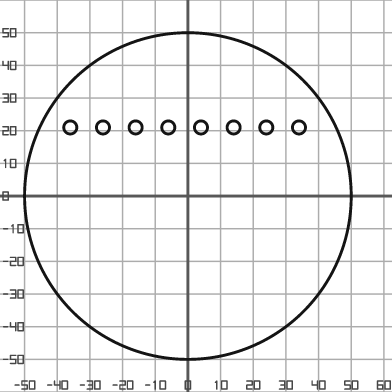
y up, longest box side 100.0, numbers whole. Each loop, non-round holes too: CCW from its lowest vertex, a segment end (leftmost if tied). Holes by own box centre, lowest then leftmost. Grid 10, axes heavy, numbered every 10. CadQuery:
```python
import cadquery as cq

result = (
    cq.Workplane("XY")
    .moveTo(0.0, 0.0)
    .circle(50.0)
    .moveTo(-36.0, 21.0)
    .circle(2.0)
    .moveTo(-26.0, 21.0)
    .circle(2.0)
    .moveTo(-16.0, 21.0)
    .circle(2.0)
    .moveTo(-6.0, 21.0)
    .circle(2.0)
    .moveTo(4.0, 21.0)
    .circle(2.0)
    .moveTo(14.0, 21.0)
    .circle(2.0)
    .moveTo(24.0, 21.0)
    .circle(2.0)
    .moveTo(34.0, 21.0)
    .circle(2.0)
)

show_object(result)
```